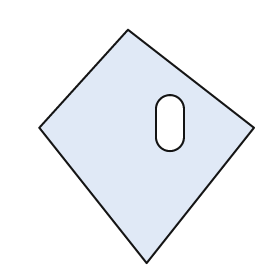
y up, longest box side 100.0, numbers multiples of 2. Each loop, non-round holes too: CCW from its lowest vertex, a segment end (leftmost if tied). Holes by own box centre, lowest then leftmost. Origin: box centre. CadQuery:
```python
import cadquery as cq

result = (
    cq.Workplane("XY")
    .moveTo(0.0, -50.0)
    .lineTo(46.0, 8.0)
    .lineTo(-8.0, 50.0)
    .lineTo(-46.0, 8.0)
    .close()
    .moveTo(4.0, 4.0)
    .threePointArc((10.0, -2.0), (16.0, 4.0))
    .lineTo(16.0, 16.0)
    .threePointArc((10.0, 22.0), (4.0, 16.0))
    .close()
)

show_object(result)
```